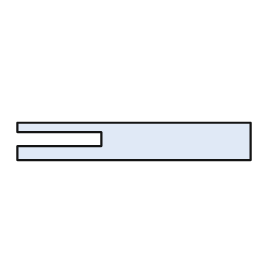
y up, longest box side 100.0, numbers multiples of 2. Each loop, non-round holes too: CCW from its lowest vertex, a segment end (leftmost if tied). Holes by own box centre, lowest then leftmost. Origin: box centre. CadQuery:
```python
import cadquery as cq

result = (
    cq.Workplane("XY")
    .moveTo(-50.0, -8.0)
    .lineTo(50.0, -8.0)
    .lineTo(50.0, 8.0)
    .lineTo(-50.0, 8.0)
    .lineTo(-50.0, 4.0)
    .lineTo(-14.0, 4.0)
    .lineTo(-14.0, -2.0)
    .lineTo(-50.0, -2.0)
    .close()
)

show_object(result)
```